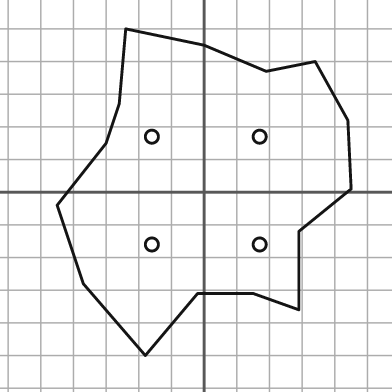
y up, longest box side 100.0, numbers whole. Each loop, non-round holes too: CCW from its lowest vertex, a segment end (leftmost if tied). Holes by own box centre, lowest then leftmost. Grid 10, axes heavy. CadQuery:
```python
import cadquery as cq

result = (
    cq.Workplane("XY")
    .moveTo(-18.0, -50.0)
    .lineTo(-2.0, -31.0)
    .lineTo(15.0, -31.0)
    .lineTo(29.0, -36.0)
    .lineTo(29.0, -12.0)
    .lineTo(45.0, 1.0)
    .lineTo(44.0, 22.0)
    .lineTo(34.0, 40.0)
    .lineTo(19.0, 37.0)
    .lineTo(0.0, 45.0)
    .lineTo(-24.0, 50.0)
    .lineTo(-26.0, 27.0)
    .lineTo(-30.0, 15.0)
    .lineTo(-45.0, -4.0)
    .lineTo(-37.0, -28.0)
    .close()
    .moveTo(-16.0, -16.0)
    .circle(2.0)
    .moveTo(17.0, -16.0)
    .circle(2.0)
    .moveTo(-16.0, 17.0)
    .circle(2.0)
    .moveTo(17.0, 17.0)
    .circle(2.0)
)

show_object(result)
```